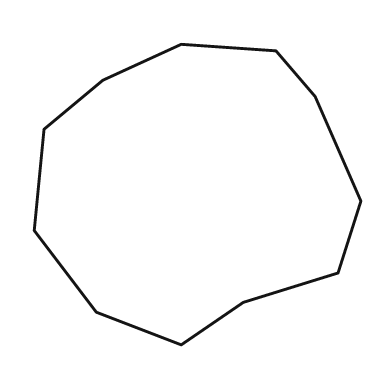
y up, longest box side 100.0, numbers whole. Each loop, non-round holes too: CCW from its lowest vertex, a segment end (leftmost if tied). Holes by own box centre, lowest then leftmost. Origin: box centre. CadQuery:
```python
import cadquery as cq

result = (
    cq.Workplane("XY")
    .moveTo(-5.0, -46.0)
    .lineTo(14.0, -33.0)
    .lineTo(43.0, -24.0)
    .lineTo(50.0, -2.0)
    .lineTo(36.0, 30.0)
    .lineTo(24.0, 44.0)
    .lineTo(-5.0, 46.0)
    .lineTo(-29.0, 35.0)
    .lineTo(-47.0, 20.0)
    .lineTo(-50.0, -11.0)
    .lineTo(-31.0, -36.0)
    .close()
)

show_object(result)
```